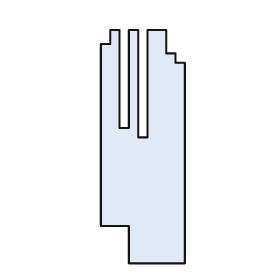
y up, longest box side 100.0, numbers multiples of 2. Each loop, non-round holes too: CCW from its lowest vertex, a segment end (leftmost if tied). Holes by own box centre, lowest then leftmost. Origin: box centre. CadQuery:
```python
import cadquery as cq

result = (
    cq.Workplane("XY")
    .moveTo(-6.0, -50.0)
    .lineTo(18.0, -50.0)
    .lineTo(18.0, 36.0)
    .lineTo(14.0, 36.0)
    .lineTo(14.0, 40.0)
    .lineTo(10.0, 40.0)
    .lineTo(10.0, 50.0)
    .lineTo(2.0, 50.0)
    .lineTo(2.0, 4.0)
    .lineTo(-2.0, 4.0)
    .lineTo(-2.0, 50.0)
    .lineTo(-6.0, 50.0)
    .lineTo(-6.0, 8.0)
    .lineTo(-10.0, 8.0)
    .lineTo(-10.0, 50.0)
    .lineTo(-14.0, 50.0)
    .lineTo(-14.0, 44.0)
    .lineTo(-18.0, 44.0)
    .lineTo(-18.0, -34.0)
    .lineTo(-6.0, -34.0)
    .close()
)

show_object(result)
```